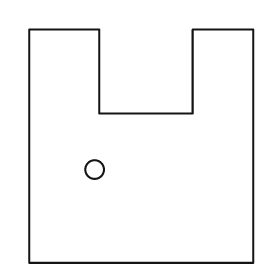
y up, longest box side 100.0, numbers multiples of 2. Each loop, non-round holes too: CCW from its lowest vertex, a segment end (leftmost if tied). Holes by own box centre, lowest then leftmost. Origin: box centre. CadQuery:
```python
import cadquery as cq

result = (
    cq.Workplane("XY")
    .moveTo(-48.0, -50.0)
    .lineTo(48.0, -50.0)
    .lineTo(48.0, 50.0)
    .lineTo(22.0, 50.0)
    .lineTo(22.0, 14.0)
    .lineTo(-18.0, 14.0)
    .lineTo(-18.0, 50.0)
    .lineTo(-48.0, 50.0)
    .close()
    .moveTo(-20.0, -10.0)
    .circle(4.0)
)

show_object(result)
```